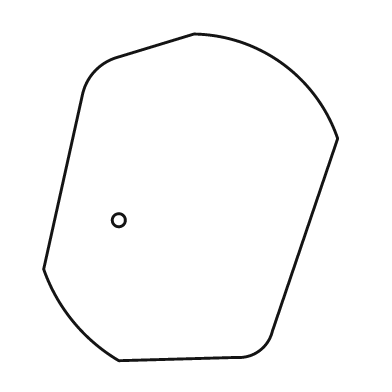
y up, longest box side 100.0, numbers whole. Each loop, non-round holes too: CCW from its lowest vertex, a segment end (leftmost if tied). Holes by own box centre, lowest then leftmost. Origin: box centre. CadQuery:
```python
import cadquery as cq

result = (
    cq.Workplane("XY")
    .moveTo(-22.0, -50.0)
    .lineTo(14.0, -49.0)
    .threePointArc((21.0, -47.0), (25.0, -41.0))
    .lineTo(45.0, 18.0)
    .threePointArc((28.0, 41.0), (1.0, 50.0))
    .lineTo(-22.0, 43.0)
    .threePointArc((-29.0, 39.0), (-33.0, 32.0))
    .lineTo(-45.0, -22.0)
    .threePointArc((-36.0, -38.0), (-22.0, -50.0))
    .close()
    .moveTo(-22.0, -7.0)
    .circle(2.0)
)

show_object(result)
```